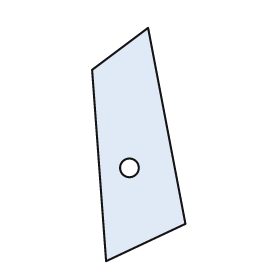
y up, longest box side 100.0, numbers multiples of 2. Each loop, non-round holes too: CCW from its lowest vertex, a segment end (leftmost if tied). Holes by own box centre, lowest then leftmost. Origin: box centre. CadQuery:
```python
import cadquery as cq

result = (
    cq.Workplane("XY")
    .moveTo(-14.0, -50.0)
    .lineTo(20.0, -34.0)
    .lineTo(4.0, 50.0)
    .lineTo(-20.0, 32.0)
    .close()
    .moveTo(-4.0, -10.0)
    .circle(4.0)
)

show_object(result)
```